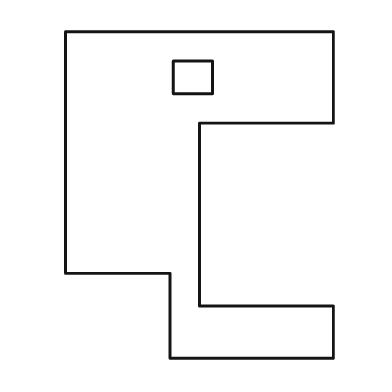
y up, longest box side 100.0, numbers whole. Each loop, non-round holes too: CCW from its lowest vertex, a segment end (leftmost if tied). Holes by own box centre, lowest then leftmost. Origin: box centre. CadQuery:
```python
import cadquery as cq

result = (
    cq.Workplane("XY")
    .moveTo(-9.0, -50.0)
    .lineTo(41.0, -50.0)
    .lineTo(41.0, -34.0)
    .lineTo(0.0, -34.0)
    .lineTo(0.0, 22.0)
    .lineTo(41.0, 22.0)
    .lineTo(41.0, 50.0)
    .lineTo(-41.0, 50.0)
    .lineTo(-41.0, -24.0)
    .lineTo(-9.0, -24.0)
    .close()
    .moveTo(-8.0, 31.0)
    .lineTo(4.0, 31.0)
    .lineTo(4.0, 41.0)
    .lineTo(-8.0, 41.0)
    .close()
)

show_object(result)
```